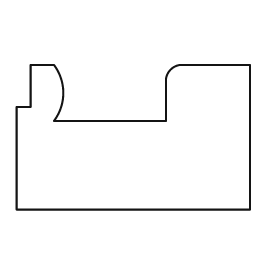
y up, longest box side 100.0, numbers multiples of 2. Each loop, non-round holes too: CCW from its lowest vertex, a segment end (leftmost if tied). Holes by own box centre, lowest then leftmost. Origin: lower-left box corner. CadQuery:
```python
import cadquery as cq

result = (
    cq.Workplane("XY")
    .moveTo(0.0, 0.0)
    .lineTo(100.0, 0.0)
    .lineTo(100.0, 62.0)
    .lineTo(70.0, 62.0)
    .threePointArc((66.0, 60.0), (64.0, 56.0))
    .lineTo(64.0, 38.0)
    .lineTo(16.0, 38.0)
    .threePointArc((20.0, 50.0), (16.0, 62.0))
    .lineTo(6.0, 62.0)
    .lineTo(6.0, 44.0)
    .lineTo(0.0, 44.0)
    .close()
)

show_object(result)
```